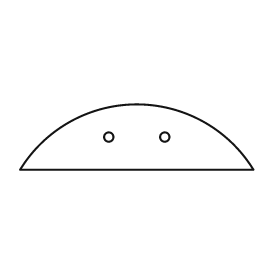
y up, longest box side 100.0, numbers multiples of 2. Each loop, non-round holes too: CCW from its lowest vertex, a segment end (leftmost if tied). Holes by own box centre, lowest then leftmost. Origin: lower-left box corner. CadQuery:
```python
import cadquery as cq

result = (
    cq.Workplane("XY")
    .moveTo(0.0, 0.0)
    .lineTo(100.0, 0.0)
    .threePointArc((50.0, 28.0), (0.0, 0.0))
    .close()
    .moveTo(38.0, 14.0)
    .circle(2.0)
    .moveTo(62.0, 14.0)
    .circle(2.0)
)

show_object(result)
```